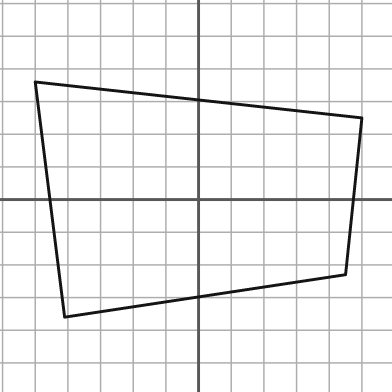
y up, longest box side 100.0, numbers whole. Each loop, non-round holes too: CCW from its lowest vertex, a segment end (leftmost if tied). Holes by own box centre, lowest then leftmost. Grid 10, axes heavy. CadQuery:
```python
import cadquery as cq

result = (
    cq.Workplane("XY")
    .moveTo(-41.0, -36.0)
    .lineTo(45.0, -23.0)
    .lineTo(50.0, 25.0)
    .lineTo(-50.0, 36.0)
    .close()
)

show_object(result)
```